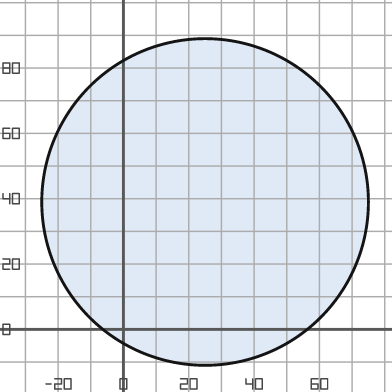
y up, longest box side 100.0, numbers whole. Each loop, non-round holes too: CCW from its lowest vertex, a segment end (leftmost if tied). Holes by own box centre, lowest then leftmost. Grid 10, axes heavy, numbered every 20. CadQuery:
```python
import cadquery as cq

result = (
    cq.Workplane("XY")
    .moveTo(25.0, 39.0)
    .circle(50.0)
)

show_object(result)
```